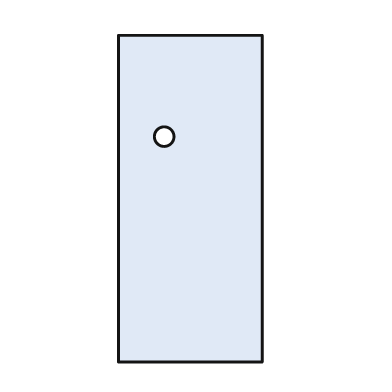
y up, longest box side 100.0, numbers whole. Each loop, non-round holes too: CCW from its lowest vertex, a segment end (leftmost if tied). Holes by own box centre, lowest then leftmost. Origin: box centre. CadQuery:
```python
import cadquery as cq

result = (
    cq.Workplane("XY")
    .moveTo(-22.0, -50.0)
    .lineTo(22.0, -50.0)
    .lineTo(22.0, 50.0)
    .lineTo(-22.0, 50.0)
    .close()
    .moveTo(-8.0, 19.0)
    .circle(3.0)
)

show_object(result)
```